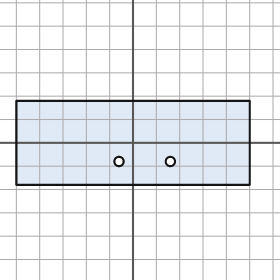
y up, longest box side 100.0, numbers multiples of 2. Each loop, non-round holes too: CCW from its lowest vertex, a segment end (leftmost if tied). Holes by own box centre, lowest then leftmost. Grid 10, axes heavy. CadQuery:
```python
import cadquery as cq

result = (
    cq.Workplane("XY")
    .moveTo(-50.0, -18.0)
    .lineTo(50.0, -18.0)
    .lineTo(50.0, 18.0)
    .lineTo(-50.0, 18.0)
    .close()
    .moveTo(-6.0, -8.0)
    .circle(2.0)
    .moveTo(16.0, -8.0)
    .circle(2.0)
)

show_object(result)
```